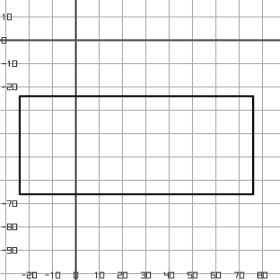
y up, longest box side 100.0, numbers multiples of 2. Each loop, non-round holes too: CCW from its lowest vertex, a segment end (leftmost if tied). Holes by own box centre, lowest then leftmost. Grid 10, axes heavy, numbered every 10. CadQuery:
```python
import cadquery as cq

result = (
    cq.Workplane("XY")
    .moveTo(-24.0, -66.0)
    .lineTo(76.0, -66.0)
    .lineTo(76.0, -24.0)
    .lineTo(-24.0, -24.0)
    .close()
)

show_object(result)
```